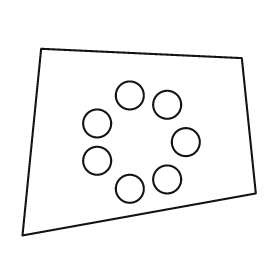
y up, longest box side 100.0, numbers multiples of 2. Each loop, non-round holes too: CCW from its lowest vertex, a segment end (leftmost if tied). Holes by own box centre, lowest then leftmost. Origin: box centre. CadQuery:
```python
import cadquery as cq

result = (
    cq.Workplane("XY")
    .moveTo(-50.0, -40.0)
    .lineTo(50.0, -22.0)
    .lineTo(44.0, 36.0)
    .lineTo(-42.0, 40.0)
    .close()
    .moveTo(-4.0, -20.0)
    .circle(6.0)
    .moveTo(12.0, -16.0)
    .circle(6.0)
    .moveTo(-18.0, -8.0)
    .circle(6.0)
    .moveTo(20.0, 0.0)
    .circle(6.0)
    .moveTo(-18.0, 8.0)
    .circle(6.0)
    .moveTo(12.0, 16.0)
    .circle(6.0)
    .moveTo(-4.0, 20.0)
    .circle(6.0)
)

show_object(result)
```